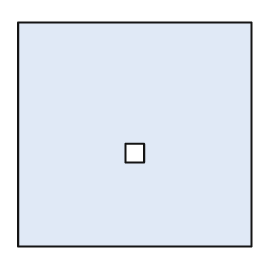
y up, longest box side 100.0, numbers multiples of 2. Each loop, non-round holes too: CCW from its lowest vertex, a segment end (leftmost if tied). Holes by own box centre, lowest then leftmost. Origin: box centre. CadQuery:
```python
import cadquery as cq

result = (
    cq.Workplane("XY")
    .moveTo(-50.0, -48.0)
    .lineTo(50.0, -48.0)
    .lineTo(50.0, 48.0)
    .lineTo(-50.0, 48.0)
    .close()
    .moveTo(-4.0, -12.0)
    .lineTo(4.0, -12.0)
    .lineTo(4.0, -4.0)
    .lineTo(-4.0, -4.0)
    .close()
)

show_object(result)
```